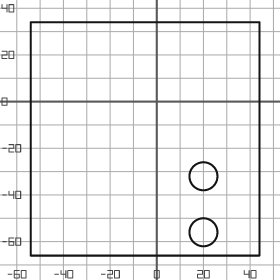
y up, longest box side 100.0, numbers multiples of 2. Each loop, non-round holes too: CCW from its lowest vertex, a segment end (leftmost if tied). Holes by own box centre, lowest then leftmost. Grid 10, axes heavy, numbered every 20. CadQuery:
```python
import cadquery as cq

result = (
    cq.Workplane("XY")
    .moveTo(-54.0, -66.0)
    .lineTo(44.0, -66.0)
    .lineTo(44.0, 34.0)
    .lineTo(-54.0, 34.0)
    .close()
    .moveTo(20.0, -56.0)
    .circle(6.0)
    .moveTo(20.0, -32.0)
    .circle(6.0)
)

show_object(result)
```